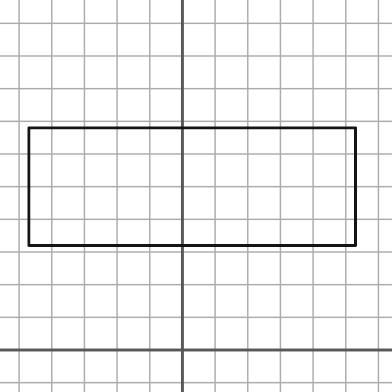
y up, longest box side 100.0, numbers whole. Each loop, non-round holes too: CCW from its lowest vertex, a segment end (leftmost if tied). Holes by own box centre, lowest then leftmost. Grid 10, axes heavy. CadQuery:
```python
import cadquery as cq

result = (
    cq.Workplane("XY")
    .moveTo(-47.0, 32.0)
    .lineTo(53.0, 32.0)
    .lineTo(53.0, 68.0)
    .lineTo(-47.0, 68.0)
    .close()
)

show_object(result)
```